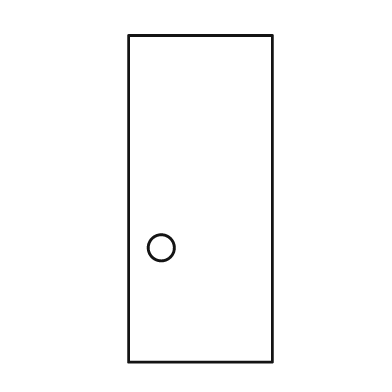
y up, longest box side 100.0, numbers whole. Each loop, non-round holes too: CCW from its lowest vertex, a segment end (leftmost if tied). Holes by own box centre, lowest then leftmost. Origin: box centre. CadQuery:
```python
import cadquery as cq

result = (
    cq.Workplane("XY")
    .moveTo(-22.0, -50.0)
    .lineTo(22.0, -50.0)
    .lineTo(22.0, 50.0)
    .lineTo(-22.0, 50.0)
    .close()
    .moveTo(-12.0, -15.0)
    .circle(4.0)
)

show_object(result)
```